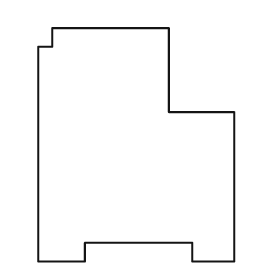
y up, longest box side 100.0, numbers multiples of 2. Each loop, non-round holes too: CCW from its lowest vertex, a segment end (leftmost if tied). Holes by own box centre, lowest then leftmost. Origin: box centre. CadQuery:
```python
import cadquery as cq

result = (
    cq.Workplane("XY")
    .moveTo(-42.0, -50.0)
    .lineTo(-22.0, -50.0)
    .lineTo(-22.0, -42.0)
    .lineTo(24.0, -42.0)
    .lineTo(24.0, -50.0)
    .lineTo(42.0, -50.0)
    .lineTo(42.0, 14.0)
    .lineTo(14.0, 14.0)
    .lineTo(14.0, 50.0)
    .lineTo(-36.0, 50.0)
    .lineTo(-36.0, 42.0)
    .lineTo(-42.0, 42.0)
    .close()
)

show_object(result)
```